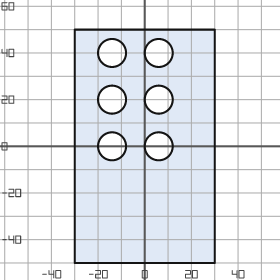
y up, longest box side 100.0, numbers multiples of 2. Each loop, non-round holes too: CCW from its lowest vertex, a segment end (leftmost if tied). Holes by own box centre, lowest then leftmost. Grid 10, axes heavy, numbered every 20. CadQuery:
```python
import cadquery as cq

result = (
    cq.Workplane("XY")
    .moveTo(-30.0, -50.0)
    .lineTo(30.0, -50.0)
    .lineTo(30.0, 50.0)
    .lineTo(-30.0, 50.0)
    .close()
    .moveTo(-14.0, 0.0)
    .circle(6.0)
    .moveTo(6.0, 0.0)
    .circle(6.0)
    .moveTo(-14.0, 20.0)
    .circle(6.0)
    .moveTo(6.0, 20.0)
    .circle(6.0)
    .moveTo(-14.0, 40.0)
    .circle(6.0)
    .moveTo(6.0, 40.0)
    .circle(6.0)
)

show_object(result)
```